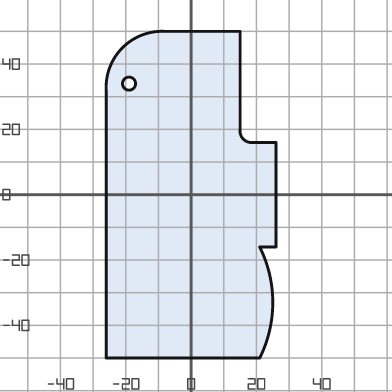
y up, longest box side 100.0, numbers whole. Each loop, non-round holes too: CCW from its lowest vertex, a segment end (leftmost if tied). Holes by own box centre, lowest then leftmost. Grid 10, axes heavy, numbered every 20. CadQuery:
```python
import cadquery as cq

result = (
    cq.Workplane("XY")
    .moveTo(-26.0, -50.0)
    .lineTo(21.0, -50.0)
    .threePointArc((25.0, -33.0), (21.0, -16.0))
    .lineTo(26.0, -16.0)
    .lineTo(26.0, 16.0)
    .lineTo(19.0, 16.0)
    .threePointArc((16.0, 17.0), (15.0, 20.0))
    .lineTo(15.0, 50.0)
    .lineTo(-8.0, 50.0)
    .threePointArc((-21.0, 45.0), (-26.0, 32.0))
    .close()
    .moveTo(-19.0, 34.0)
    .circle(2.0)
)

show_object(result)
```